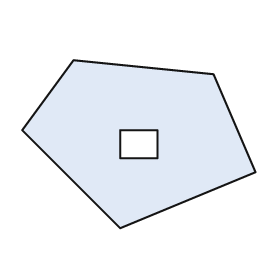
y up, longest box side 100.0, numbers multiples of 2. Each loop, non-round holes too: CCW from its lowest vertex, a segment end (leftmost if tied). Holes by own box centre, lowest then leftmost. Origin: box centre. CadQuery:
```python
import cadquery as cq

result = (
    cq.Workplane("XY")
    .moveTo(-8.0, -36.0)
    .lineTo(50.0, -12.0)
    .lineTo(32.0, 30.0)
    .lineTo(-28.0, 36.0)
    .lineTo(-50.0, 6.0)
    .close()
    .moveTo(-8.0, -6.0)
    .lineTo(8.0, -6.0)
    .lineTo(8.0, 6.0)
    .lineTo(-8.0, 6.0)
    .close()
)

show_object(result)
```